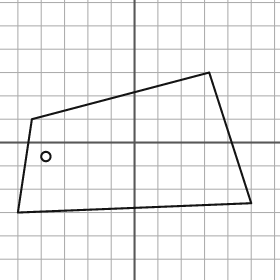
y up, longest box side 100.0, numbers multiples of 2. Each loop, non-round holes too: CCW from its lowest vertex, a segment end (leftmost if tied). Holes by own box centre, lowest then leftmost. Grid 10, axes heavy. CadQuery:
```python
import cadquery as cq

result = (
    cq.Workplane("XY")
    .moveTo(-50.0, -30.0)
    .lineTo(50.0, -26.0)
    .lineTo(32.0, 30.0)
    .lineTo(-44.0, 10.0)
    .close()
    .moveTo(-38.0, -6.0)
    .circle(2.0)
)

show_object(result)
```